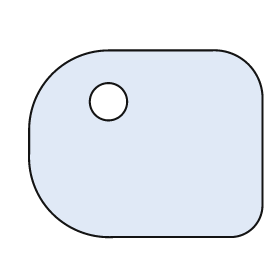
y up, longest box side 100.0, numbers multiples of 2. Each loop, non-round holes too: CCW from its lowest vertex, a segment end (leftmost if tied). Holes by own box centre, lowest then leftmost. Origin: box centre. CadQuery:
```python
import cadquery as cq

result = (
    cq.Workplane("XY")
    .moveTo(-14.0, -40.0)
    .lineTo(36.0, -40.0)
    .threePointArc((46.0, -36.0), (50.0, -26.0))
    .lineTo(50.0, 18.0)
    .threePointArc((44.0, 34.0), (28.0, 40.0))
    .lineTo(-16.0, 40.0)
    .threePointArc((-40.0, 30.0), (-50.0, 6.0))
    .lineTo(-50.0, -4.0)
    .threePointArc((-40.0, -30.0), (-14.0, -40.0))
    .close()
    .moveTo(-16.0, 18.0)
    .circle(8.0)
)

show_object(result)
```